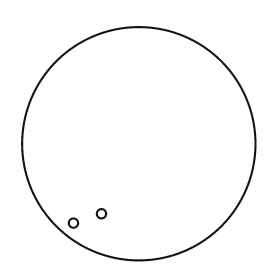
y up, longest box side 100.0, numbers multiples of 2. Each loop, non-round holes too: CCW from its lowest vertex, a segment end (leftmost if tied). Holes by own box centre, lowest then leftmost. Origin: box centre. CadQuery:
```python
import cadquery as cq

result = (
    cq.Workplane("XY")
    .moveTo(0.0, 0.0)
    .circle(50.0)
    .moveTo(-28.0, -34.0)
    .circle(2.0)
    .moveTo(-16.0, -30.0)
    .circle(2.0)
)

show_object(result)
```